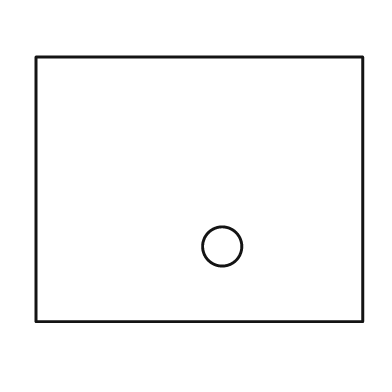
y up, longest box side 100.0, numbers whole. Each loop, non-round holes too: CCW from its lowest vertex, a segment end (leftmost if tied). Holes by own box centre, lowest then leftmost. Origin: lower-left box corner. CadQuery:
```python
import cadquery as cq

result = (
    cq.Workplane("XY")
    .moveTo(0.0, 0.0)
    .lineTo(100.0, 0.0)
    .lineTo(100.0, 81.0)
    .lineTo(0.0, 81.0)
    .close()
    .moveTo(57.0, 23.0)
    .circle(6.0)
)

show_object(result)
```